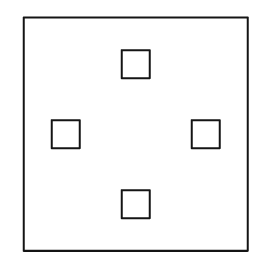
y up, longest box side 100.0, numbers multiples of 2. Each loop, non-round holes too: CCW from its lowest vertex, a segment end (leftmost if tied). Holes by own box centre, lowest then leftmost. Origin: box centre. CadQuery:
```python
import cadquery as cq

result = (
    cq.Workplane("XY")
    .moveTo(-48.0, -50.0)
    .lineTo(48.0, -50.0)
    .lineTo(48.0, 50.0)
    .lineTo(-48.0, 50.0)
    .close()
    .moveTo(-6.0, -36.0)
    .lineTo(6.0, -36.0)
    .lineTo(6.0, -24.0)
    .lineTo(-6.0, -24.0)
    .close()
    .moveTo(-36.0, -6.0)
    .lineTo(-24.0, -6.0)
    .lineTo(-24.0, 6.0)
    .lineTo(-36.0, 6.0)
    .close()
    .moveTo(24.0, -6.0)
    .lineTo(36.0, -6.0)
    .lineTo(36.0, 6.0)
    .lineTo(24.0, 6.0)
    .close()
    .moveTo(-6.0, 24.0)
    .lineTo(6.0, 24.0)
    .lineTo(6.0, 36.0)
    .lineTo(-6.0, 36.0)
    .close()
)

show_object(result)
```